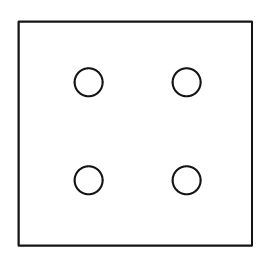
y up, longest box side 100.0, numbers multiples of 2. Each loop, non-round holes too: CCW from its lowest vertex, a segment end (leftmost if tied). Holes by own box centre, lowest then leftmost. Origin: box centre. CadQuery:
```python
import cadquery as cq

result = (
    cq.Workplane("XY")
    .moveTo(-50.0, -48.0)
    .lineTo(50.0, -48.0)
    .lineTo(50.0, 48.0)
    .lineTo(-50.0, 48.0)
    .close()
    .moveTo(-20.0, -20.0)
    .circle(6.0)
    .moveTo(22.0, -20.0)
    .circle(6.0)
    .moveTo(-20.0, 22.0)
    .circle(6.0)
    .moveTo(22.0, 22.0)
    .circle(6.0)
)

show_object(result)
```